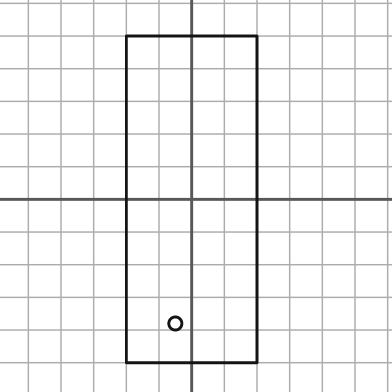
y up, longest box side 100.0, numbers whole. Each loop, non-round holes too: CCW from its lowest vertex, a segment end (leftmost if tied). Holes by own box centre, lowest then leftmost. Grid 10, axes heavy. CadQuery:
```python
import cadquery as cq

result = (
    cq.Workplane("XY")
    .moveTo(-20.0, -50.0)
    .lineTo(20.0, -50.0)
    .lineTo(20.0, 50.0)
    .lineTo(-20.0, 50.0)
    .close()
    .moveTo(-5.0, -38.0)
    .circle(2.0)
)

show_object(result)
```